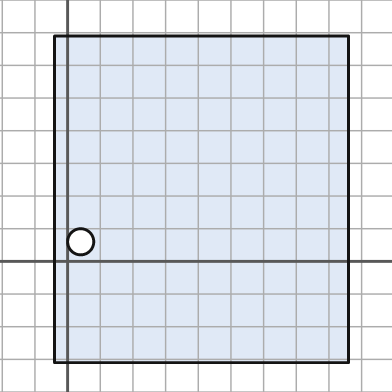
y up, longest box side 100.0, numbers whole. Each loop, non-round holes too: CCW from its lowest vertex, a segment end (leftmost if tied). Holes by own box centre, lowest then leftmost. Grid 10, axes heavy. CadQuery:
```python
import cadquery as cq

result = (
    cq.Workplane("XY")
    .moveTo(-4.0, -31.0)
    .lineTo(86.0, -31.0)
    .lineTo(86.0, 69.0)
    .lineTo(-4.0, 69.0)
    .close()
    .moveTo(4.0, 6.0)
    .circle(4.0)
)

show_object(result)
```